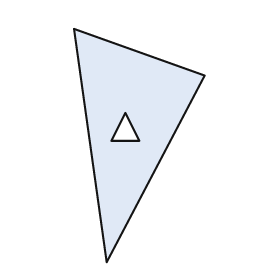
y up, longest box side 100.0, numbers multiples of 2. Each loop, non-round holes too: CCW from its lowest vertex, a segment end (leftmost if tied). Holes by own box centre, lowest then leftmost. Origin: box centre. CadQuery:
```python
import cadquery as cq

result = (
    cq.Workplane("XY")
    .moveTo(-14.0, -50.0)
    .lineTo(28.0, 30.0)
    .lineTo(-28.0, 50.0)
    .close()
    .moveTo(-12.0, 2.0)
    .lineTo(0.0, 2.0)
    .lineTo(-6.0, 14.0)
    .close()
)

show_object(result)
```